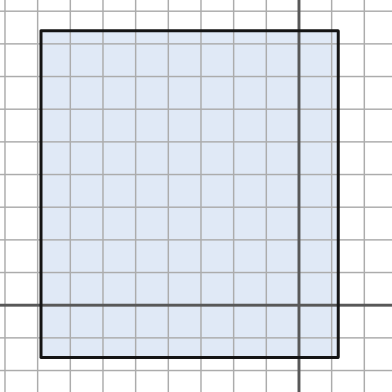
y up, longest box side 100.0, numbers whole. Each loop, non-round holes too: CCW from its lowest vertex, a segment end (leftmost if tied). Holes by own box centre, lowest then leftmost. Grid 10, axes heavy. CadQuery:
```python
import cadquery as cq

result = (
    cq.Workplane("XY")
    .moveTo(-79.0, -16.0)
    .lineTo(12.0, -16.0)
    .lineTo(12.0, 84.0)
    .lineTo(-79.0, 84.0)
    .close()
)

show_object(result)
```